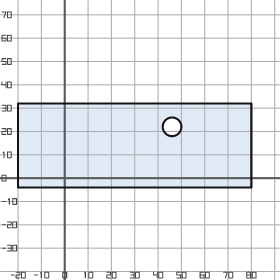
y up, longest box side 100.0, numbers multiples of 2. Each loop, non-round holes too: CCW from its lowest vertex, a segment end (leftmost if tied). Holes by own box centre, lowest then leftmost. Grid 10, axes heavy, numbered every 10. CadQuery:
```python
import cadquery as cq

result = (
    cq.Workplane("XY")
    .moveTo(-20.0, -4.0)
    .lineTo(80.0, -4.0)
    .lineTo(80.0, 32.0)
    .lineTo(-20.0, 32.0)
    .close()
    .moveTo(46.0, 22.0)
    .circle(4.0)
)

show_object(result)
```